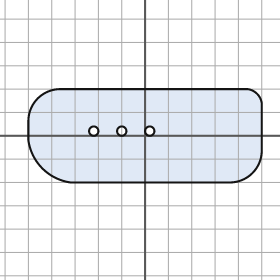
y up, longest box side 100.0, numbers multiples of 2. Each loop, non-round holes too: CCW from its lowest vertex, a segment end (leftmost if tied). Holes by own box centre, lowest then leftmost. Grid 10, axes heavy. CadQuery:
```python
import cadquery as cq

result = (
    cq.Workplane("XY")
    .moveTo(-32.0, -20.0)
    .lineTo(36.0, -20.0)
    .threePointArc((46.0, -16.0), (50.0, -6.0))
    .lineTo(50.0, 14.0)
    .threePointArc((48.0, 18.0), (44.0, 20.0))
    .lineTo(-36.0, 20.0)
    .threePointArc((-46.0, 16.0), (-50.0, 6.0))
    .lineTo(-50.0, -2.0)
    .threePointArc((-44.0, -14.0), (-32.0, -20.0))
    .close()
    .moveTo(-22.0, 2.0)
    .circle(2.0)
    .moveTo(-10.0, 2.0)
    .circle(2.0)
    .moveTo(2.0, 2.0)
    .circle(2.0)
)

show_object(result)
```